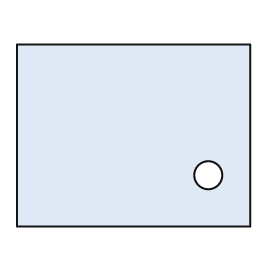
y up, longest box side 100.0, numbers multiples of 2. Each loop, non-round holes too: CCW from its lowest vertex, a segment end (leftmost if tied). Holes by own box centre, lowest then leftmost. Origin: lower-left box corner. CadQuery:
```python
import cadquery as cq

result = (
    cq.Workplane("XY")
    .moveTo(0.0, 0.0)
    .lineTo(100.0, 0.0)
    .lineTo(100.0, 78.0)
    .lineTo(0.0, 78.0)
    .close()
    .moveTo(82.0, 22.0)
    .circle(6.0)
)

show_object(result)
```